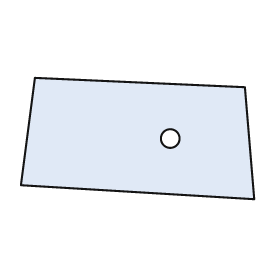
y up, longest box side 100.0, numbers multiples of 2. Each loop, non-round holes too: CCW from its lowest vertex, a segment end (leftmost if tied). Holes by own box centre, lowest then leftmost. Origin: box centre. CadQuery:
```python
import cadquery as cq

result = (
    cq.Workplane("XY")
    .moveTo(50.0, -26.0)
    .lineTo(46.0, 22.0)
    .lineTo(-44.0, 26.0)
    .lineTo(-50.0, -20.0)
    .close()
    .moveTo(14.0, 0.0)
    .circle(4.0)
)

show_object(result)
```